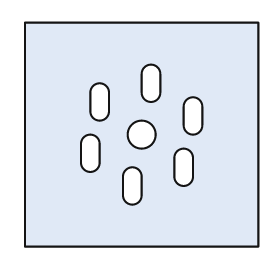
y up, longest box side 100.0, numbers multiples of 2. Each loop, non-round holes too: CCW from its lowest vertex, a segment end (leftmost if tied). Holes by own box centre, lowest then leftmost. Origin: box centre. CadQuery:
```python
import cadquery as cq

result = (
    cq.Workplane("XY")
    .moveTo(-50.0, -48.0)
    .lineTo(50.0, -48.0)
    .lineTo(50.0, 48.0)
    .lineTo(-50.0, 48.0)
    .close()
    .moveTo(-8.0, -26.0)
    .threePointArc((-4.0, -30.0), (0.0, -26.0))
    .lineTo(0.0, -18.0)
    .threePointArc((-4.0, -14.0), (-8.0, -18.0))
    .close()
    .moveTo(14.0, -18.0)
    .threePointArc((18.0, -22.0), (22.0, -18.0))
    .lineTo(22.0, -10.0)
    .threePointArc((18.0, -6.0), (14.0, -10.0))
    .close()
    .moveTo(-26.0, -12.0)
    .threePointArc((-22.0, -16.0), (-18.0, -12.0))
    .lineTo(-18.0, -4.0)
    .threePointArc((-22.0, 0.0), (-26.0, -4.0))
    .close()
    .moveTo(0.0, 0.0)
    .circle(6.0)
    .moveTo(18.0, 4.0)
    .threePointArc((22.0, 0.0), (26.0, 4.0))
    .lineTo(26.0, 12.0)
    .threePointArc((22.0, 16.0), (18.0, 12.0))
    .close()
    .moveTo(-22.0, 10.0)
    .threePointArc((-18.0, 6.0), (-14.0, 10.0))
    .lineTo(-14.0, 18.0)
    .threePointArc((-18.0, 22.0), (-22.0, 18.0))
    .close()
    .moveTo(0.0, 18.0)
    .threePointArc((4.0, 14.0), (8.0, 18.0))
    .lineTo(8.0, 26.0)
    .threePointArc((4.0, 30.0), (0.0, 26.0))
    .close()
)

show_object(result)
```